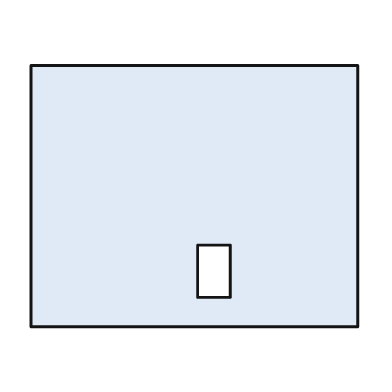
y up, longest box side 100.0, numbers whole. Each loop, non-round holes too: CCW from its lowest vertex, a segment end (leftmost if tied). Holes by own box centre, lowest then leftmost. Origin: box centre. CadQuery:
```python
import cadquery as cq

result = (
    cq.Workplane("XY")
    .moveTo(-50.0, -40.0)
    .lineTo(50.0, -40.0)
    .lineTo(50.0, 40.0)
    .lineTo(-50.0, 40.0)
    .close()
    .moveTo(1.0, -31.0)
    .lineTo(11.0, -31.0)
    .lineTo(11.0, -15.0)
    .lineTo(1.0, -15.0)
    .close()
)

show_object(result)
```